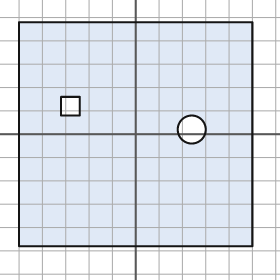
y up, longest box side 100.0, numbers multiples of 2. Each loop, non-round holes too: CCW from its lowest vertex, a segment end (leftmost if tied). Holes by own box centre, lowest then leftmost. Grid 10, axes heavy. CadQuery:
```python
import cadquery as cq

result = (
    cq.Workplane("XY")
    .moveTo(-50.0, -48.0)
    .lineTo(50.0, -48.0)
    .lineTo(50.0, 48.0)
    .lineTo(-50.0, 48.0)
    .close()
    .moveTo(24.0, 2.0)
    .circle(6.0)
    .moveTo(-32.0, 8.0)
    .lineTo(-24.0, 8.0)
    .lineTo(-24.0, 16.0)
    .lineTo(-32.0, 16.0)
    .close()
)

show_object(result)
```